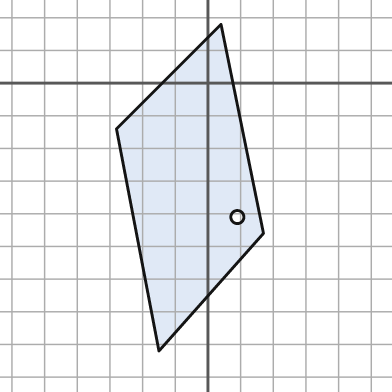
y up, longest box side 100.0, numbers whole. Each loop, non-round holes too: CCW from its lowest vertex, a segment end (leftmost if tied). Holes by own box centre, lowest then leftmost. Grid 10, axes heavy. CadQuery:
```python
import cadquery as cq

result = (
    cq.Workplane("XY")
    .moveTo(-15.0, -82.0)
    .lineTo(17.0, -46.0)
    .lineTo(4.0, 18.0)
    .lineTo(-28.0, -14.0)
    .close()
    .moveTo(9.0, -41.0)
    .circle(2.0)
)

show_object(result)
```